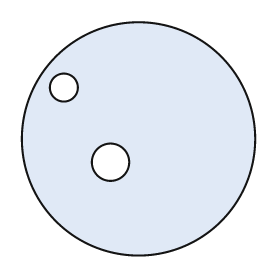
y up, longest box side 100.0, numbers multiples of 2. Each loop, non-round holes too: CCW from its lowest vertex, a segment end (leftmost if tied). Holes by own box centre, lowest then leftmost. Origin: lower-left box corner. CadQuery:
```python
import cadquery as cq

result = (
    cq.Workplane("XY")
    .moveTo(50.0, 50.0)
    .circle(50.0)
    .moveTo(38.0, 40.0)
    .circle(8.0)
    .moveTo(18.0, 72.0)
    .circle(6.0)
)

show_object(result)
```